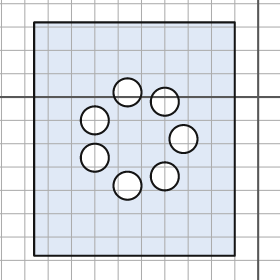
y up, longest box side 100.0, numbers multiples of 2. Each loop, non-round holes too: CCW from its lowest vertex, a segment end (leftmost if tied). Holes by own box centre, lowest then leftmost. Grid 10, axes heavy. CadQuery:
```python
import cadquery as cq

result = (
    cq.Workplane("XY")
    .moveTo(-96.0, -68.0)
    .lineTo(-10.0, -68.0)
    .lineTo(-10.0, 32.0)
    .lineTo(-96.0, 32.0)
    .close()
    .moveTo(-56.0, -38.0)
    .circle(6.0)
    .moveTo(-40.0, -34.0)
    .circle(6.0)
    .moveTo(-70.0, -26.0)
    .circle(6.0)
    .moveTo(-32.0, -18.0)
    .circle(6.0)
    .moveTo(-70.0, -10.0)
    .circle(6.0)
    .moveTo(-40.0, -2.0)
    .circle(6.0)
    .moveTo(-56.0, 2.0)
    .circle(6.0)
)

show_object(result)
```